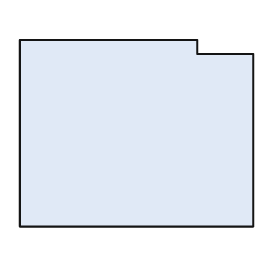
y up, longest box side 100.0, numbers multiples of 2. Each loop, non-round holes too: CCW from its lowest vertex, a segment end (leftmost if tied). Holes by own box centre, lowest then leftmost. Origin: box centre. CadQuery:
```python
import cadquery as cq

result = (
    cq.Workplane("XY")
    .moveTo(-50.0, -40.0)
    .lineTo(50.0, -40.0)
    .lineTo(50.0, 34.0)
    .lineTo(26.0, 34.0)
    .lineTo(26.0, 40.0)
    .lineTo(-50.0, 40.0)
    .close()
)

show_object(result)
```